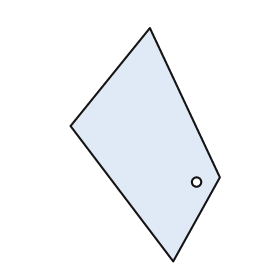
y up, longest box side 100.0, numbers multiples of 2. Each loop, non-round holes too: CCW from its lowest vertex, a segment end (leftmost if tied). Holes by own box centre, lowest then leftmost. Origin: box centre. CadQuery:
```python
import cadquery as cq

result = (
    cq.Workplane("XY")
    .moveTo(12.0, -50.0)
    .lineTo(32.0, -14.0)
    .lineTo(2.0, 50.0)
    .lineTo(-32.0, 8.0)
    .close()
    .moveTo(22.0, -16.0)
    .circle(2.0)
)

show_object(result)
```